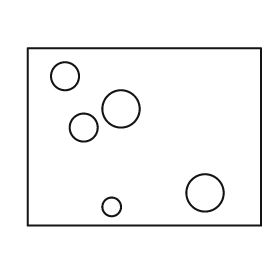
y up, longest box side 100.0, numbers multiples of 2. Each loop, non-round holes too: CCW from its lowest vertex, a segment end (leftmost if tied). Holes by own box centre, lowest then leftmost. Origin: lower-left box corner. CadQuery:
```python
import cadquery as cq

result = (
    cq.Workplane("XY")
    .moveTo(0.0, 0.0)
    .lineTo(100.0, 0.0)
    .lineTo(100.0, 76.0)
    .lineTo(0.0, 76.0)
    .close()
    .moveTo(36.0, 8.0)
    .circle(4.0)
    .moveTo(76.0, 14.0)
    .circle(8.0)
    .moveTo(24.0, 42.0)
    .circle(6.0)
    .moveTo(40.0, 50.0)
    .circle(8.0)
    .moveTo(16.0, 64.0)
    .circle(6.0)
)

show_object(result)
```